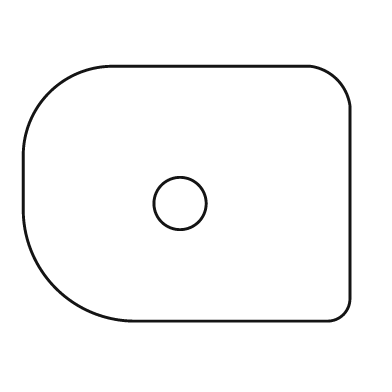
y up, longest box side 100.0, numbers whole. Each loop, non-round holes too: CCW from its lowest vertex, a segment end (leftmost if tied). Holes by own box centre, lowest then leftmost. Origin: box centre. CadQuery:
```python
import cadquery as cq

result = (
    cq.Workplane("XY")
    .moveTo(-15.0, -39.0)
    .lineTo(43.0, -39.0)
    .threePointArc((48.0, -37.0), (50.0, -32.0))
    .lineTo(50.0, 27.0)
    .threePointArc((46.0, 35.0), (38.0, 39.0))
    .lineTo(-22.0, 39.0)
    .threePointArc((-42.0, 31.0), (-50.0, 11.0))
    .lineTo(-50.0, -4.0)
    .threePointArc((-40.0, -29.0), (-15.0, -39.0))
    .close()
    .moveTo(-2.0, -3.0)
    .circle(8.0)
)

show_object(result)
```